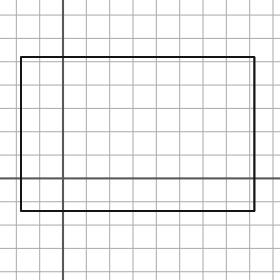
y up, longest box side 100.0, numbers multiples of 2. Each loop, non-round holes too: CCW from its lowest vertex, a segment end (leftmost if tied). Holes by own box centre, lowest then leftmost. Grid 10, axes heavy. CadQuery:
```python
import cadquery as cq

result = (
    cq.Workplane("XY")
    .moveTo(-18.0, -14.0)
    .lineTo(82.0, -14.0)
    .lineTo(82.0, 52.0)
    .lineTo(-18.0, 52.0)
    .close()
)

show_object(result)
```